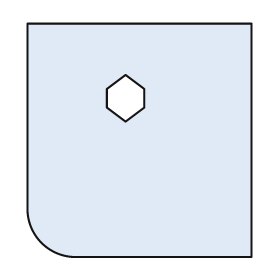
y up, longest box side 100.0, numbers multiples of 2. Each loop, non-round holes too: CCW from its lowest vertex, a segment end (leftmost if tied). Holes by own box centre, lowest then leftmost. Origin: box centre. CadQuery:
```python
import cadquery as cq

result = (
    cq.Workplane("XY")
    .moveTo(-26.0, -50.0)
    .lineTo(48.0, -50.0)
    .lineTo(48.0, 50.0)
    .lineTo(-48.0, 50.0)
    .lineTo(-48.0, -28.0)
    .threePointArc((-42.0, -44.0), (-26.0, -50.0))
    .close()
    .moveTo(-6.0, 8.0)
    .lineTo(2.0, 14.0)
    .lineTo(2.0, 22.0)
    .lineTo(-6.0, 28.0)
    .lineTo(-14.0, 22.0)
    .lineTo(-14.0, 14.0)
    .close()
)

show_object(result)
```